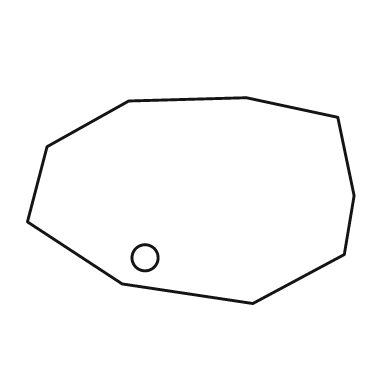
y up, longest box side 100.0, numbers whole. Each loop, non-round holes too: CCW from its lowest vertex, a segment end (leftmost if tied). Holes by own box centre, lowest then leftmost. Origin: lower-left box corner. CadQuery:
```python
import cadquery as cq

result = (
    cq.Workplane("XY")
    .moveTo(69.0, 0.0)
    .lineTo(97.0, 15.0)
    .lineTo(100.0, 33.0)
    .lineTo(95.0, 57.0)
    .lineTo(67.0, 63.0)
    .lineTo(31.0, 62.0)
    .lineTo(6.0, 48.0)
    .lineTo(0.0, 25.0)
    .lineTo(29.0, 6.0)
    .close()
    .moveTo(36.0, 14.0)
    .circle(4.0)
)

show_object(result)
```